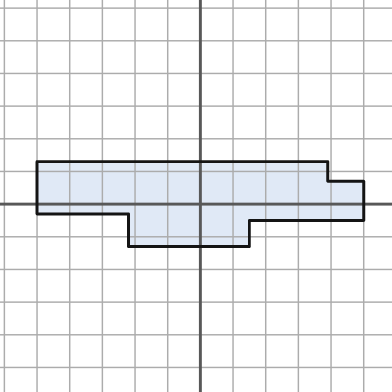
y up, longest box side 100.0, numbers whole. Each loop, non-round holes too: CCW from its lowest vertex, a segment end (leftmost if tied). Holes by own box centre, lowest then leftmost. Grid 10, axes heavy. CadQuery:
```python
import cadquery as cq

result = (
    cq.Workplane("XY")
    .moveTo(-22.0, -13.0)
    .lineTo(15.0, -13.0)
    .lineTo(15.0, -5.0)
    .lineTo(50.0, -5.0)
    .lineTo(50.0, 7.0)
    .lineTo(39.0, 7.0)
    .lineTo(39.0, 13.0)
    .lineTo(-50.0, 13.0)
    .lineTo(-50.0, -3.0)
    .lineTo(-22.0, -3.0)
    .close()
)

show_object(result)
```